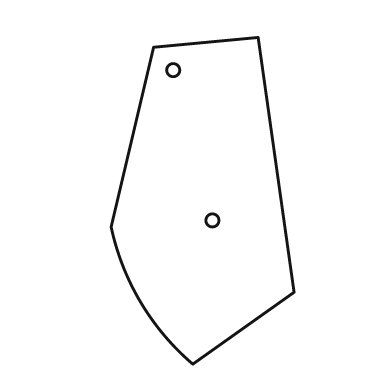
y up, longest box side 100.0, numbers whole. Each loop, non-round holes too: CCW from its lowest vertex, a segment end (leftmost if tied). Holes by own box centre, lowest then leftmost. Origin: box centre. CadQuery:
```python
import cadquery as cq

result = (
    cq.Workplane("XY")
    .moveTo(-3.0, -50.0)
    .lineTo(28.0, -28.0)
    .lineTo(17.0, 50.0)
    .lineTo(-15.0, 47.0)
    .lineTo(-28.0, -8.0)
    .threePointArc((-19.0, -31.0), (-3.0, -50.0))
    .close()
    .moveTo(3.0, -6.0)
    .circle(2.0)
    .moveTo(-9.0, 40.0)
    .circle(2.0)
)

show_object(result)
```